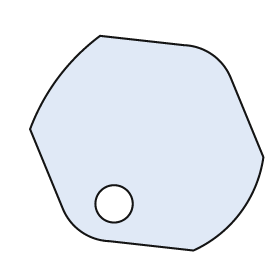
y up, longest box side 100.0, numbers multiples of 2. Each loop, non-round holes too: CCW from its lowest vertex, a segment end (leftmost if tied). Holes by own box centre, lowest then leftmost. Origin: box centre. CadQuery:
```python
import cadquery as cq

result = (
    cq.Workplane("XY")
    .moveTo(20.0, -46.0)
    .threePointArc((40.0, -30.0), (50.0, -6.0))
    .lineTo(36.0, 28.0)
    .threePointArc((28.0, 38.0), (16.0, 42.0))
    .lineTo(-20.0, 46.0)
    .threePointArc((-38.0, 28.0), (-50.0, 6.0))
    .lineTo(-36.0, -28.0)
    .threePointArc((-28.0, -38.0), (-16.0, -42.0))
    .close()
    .moveTo(-14.0, -26.0)
    .circle(8.0)
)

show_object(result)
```